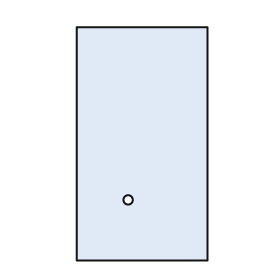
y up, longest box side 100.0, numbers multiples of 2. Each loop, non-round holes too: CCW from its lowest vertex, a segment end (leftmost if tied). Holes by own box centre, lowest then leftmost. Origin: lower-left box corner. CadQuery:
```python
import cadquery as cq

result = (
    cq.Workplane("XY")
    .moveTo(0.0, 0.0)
    .lineTo(56.0, 0.0)
    .lineTo(56.0, 100.0)
    .lineTo(0.0, 100.0)
    .close()
    .moveTo(22.0, 26.0)
    .circle(2.0)
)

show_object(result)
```